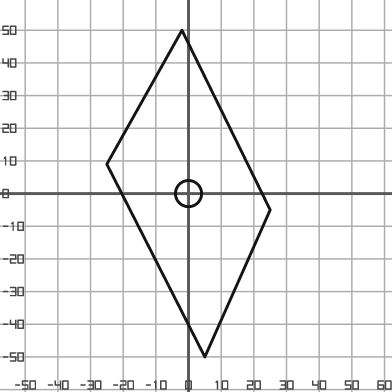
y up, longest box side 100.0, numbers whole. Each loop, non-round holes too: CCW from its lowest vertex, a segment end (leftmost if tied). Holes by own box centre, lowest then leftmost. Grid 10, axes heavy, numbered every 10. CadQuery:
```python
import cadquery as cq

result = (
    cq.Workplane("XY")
    .moveTo(5.0, -50.0)
    .lineTo(25.0, -5.0)
    .lineTo(-2.0, 50.0)
    .lineTo(-25.0, 9.0)
    .close()
    .moveTo(0.0, 0.0)
    .circle(4.0)
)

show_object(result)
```